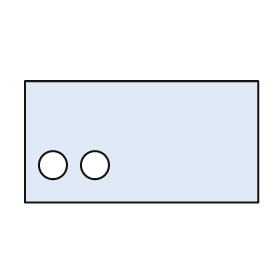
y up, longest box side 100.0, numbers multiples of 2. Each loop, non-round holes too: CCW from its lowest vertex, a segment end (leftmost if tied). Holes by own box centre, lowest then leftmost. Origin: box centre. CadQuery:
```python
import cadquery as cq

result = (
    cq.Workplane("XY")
    .moveTo(-50.0, -26.0)
    .lineTo(50.0, -26.0)
    .lineTo(50.0, 26.0)
    .lineTo(-50.0, 26.0)
    .close()
    .moveTo(-38.0, -10.0)
    .circle(6.0)
    .moveTo(-20.0, -10.0)
    .circle(6.0)
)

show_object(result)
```